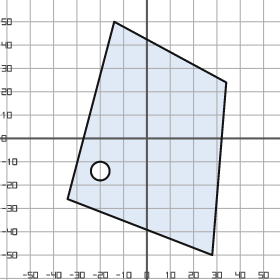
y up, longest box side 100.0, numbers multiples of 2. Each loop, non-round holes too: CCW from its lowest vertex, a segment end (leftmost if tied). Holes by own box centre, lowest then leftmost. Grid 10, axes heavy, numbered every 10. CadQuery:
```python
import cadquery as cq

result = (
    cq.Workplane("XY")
    .moveTo(28.0, -50.0)
    .lineTo(34.0, 24.0)
    .lineTo(-14.0, 50.0)
    .lineTo(-34.0, -26.0)
    .close()
    .moveTo(-20.0, -14.0)
    .circle(4.0)
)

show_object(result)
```